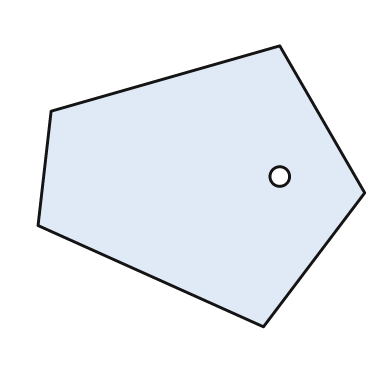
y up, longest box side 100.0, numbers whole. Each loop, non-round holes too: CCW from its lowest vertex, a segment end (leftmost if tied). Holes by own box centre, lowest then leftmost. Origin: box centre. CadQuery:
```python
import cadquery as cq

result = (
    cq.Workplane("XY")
    .moveTo(19.0, -43.0)
    .lineTo(50.0, -2.0)
    .lineTo(24.0, 43.0)
    .lineTo(-46.0, 23.0)
    .lineTo(-50.0, -12.0)
    .close()
    .moveTo(24.0, 3.0)
    .circle(3.0)
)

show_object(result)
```